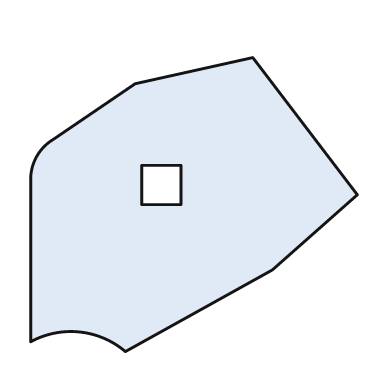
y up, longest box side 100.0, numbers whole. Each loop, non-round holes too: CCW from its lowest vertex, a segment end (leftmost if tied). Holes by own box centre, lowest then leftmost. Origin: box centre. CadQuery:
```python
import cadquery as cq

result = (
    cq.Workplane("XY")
    .moveTo(-21.0, -45.0)
    .lineTo(24.0, -20.0)
    .lineTo(50.0, 3.0)
    .lineTo(18.0, 45.0)
    .lineTo(-18.0, 37.0)
    .lineTo(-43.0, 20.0)
    .threePointArc((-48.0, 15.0), (-50.0, 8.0))
    .lineTo(-50.0, -42.0)
    .threePointArc((-35.0, -39.0), (-21.0, -45.0))
    .close()
    .moveTo(-16.0, 0.0)
    .lineTo(-4.0, 0.0)
    .lineTo(-4.0, 12.0)
    .lineTo(-16.0, 12.0)
    .close()
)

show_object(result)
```